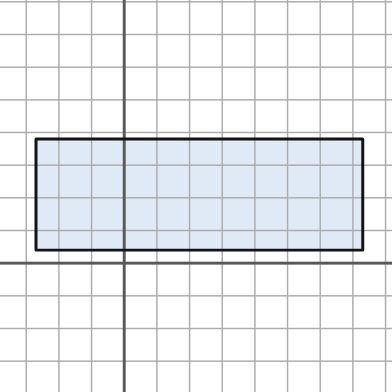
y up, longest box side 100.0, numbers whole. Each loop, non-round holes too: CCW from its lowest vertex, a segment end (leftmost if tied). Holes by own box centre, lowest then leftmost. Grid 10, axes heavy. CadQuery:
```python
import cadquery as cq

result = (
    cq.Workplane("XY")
    .moveTo(-27.0, 4.0)
    .lineTo(73.0, 4.0)
    .lineTo(73.0, 38.0)
    .lineTo(-27.0, 38.0)
    .close()
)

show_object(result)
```